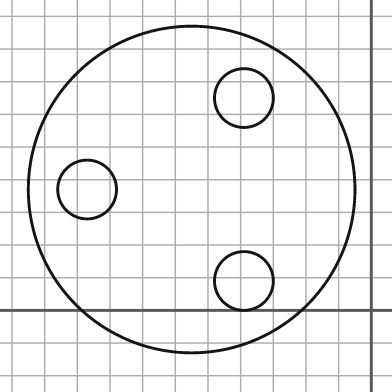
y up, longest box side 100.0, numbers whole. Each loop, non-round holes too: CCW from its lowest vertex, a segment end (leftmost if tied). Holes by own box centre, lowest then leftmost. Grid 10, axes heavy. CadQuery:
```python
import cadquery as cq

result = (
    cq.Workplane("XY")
    .moveTo(-55.0, 37.0)
    .circle(50.0)
    .moveTo(-39.0, 9.0)
    .circle(9.0)
    .moveTo(-87.0, 37.0)
    .circle(9.0)
    .moveTo(-39.0, 65.0)
    .circle(9.0)
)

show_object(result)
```